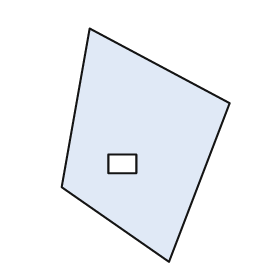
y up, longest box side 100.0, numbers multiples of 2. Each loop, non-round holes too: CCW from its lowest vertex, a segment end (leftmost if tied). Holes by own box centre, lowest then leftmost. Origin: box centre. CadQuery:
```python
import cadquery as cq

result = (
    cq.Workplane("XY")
    .moveTo(10.0, -50.0)
    .lineTo(36.0, 18.0)
    .lineTo(-24.0, 50.0)
    .lineTo(-36.0, -18.0)
    .close()
    .moveTo(-16.0, -12.0)
    .lineTo(-4.0, -12.0)
    .lineTo(-4.0, -4.0)
    .lineTo(-16.0, -4.0)
    .close()
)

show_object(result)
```